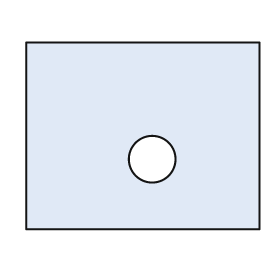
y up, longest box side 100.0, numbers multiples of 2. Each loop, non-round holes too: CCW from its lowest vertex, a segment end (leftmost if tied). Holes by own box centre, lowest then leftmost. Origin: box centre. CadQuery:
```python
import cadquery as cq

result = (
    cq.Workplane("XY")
    .moveTo(-50.0, -40.0)
    .lineTo(50.0, -40.0)
    .lineTo(50.0, 40.0)
    .lineTo(-50.0, 40.0)
    .close()
    .moveTo(4.0, -10.0)
    .circle(10.0)
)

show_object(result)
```